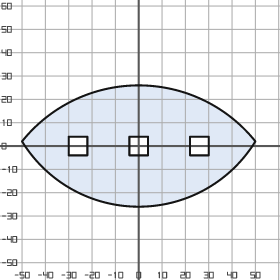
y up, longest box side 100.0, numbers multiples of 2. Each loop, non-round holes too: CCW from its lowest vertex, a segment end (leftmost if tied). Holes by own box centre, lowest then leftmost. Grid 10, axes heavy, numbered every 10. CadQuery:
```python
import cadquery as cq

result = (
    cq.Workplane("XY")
    .moveTo(-50.0, 2.0)
    .threePointArc((0.0, -26.0), (50.0, 2.0))
    .threePointArc((0.0, 26.0), (-50.0, 2.0))
    .close()
    .moveTo(-30.0, -4.0)
    .lineTo(-22.0, -4.0)
    .lineTo(-22.0, 4.0)
    .lineTo(-30.0, 4.0)
    .close()
    .moveTo(-4.0, -4.0)
    .lineTo(4.0, -4.0)
    .lineTo(4.0, 4.0)
    .lineTo(-4.0, 4.0)
    .close()
    .moveTo(22.0, -4.0)
    .lineTo(30.0, -4.0)
    .lineTo(30.0, 4.0)
    .lineTo(22.0, 4.0)
    .close()
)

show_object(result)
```